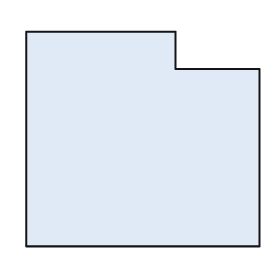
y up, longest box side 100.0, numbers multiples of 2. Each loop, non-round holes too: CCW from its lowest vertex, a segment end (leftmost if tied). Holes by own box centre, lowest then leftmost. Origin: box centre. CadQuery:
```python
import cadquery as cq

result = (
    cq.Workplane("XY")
    .moveTo(-50.0, -46.0)
    .lineTo(50.0, -46.0)
    .lineTo(50.0, 30.0)
    .lineTo(14.0, 30.0)
    .lineTo(14.0, 46.0)
    .lineTo(-50.0, 46.0)
    .close()
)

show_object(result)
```